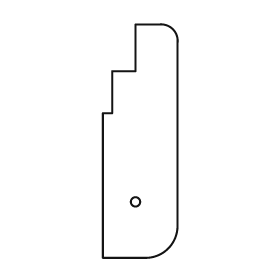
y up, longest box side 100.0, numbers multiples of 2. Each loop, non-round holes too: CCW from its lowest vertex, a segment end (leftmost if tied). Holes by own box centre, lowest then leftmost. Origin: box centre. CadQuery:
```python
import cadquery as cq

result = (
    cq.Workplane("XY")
    .moveTo(-16.0, -50.0)
    .lineTo(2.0, -50.0)
    .threePointArc((12.0, -46.0), (16.0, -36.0))
    .lineTo(16.0, 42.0)
    .threePointArc((14.0, 48.0), (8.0, 50.0))
    .lineTo(-2.0, 50.0)
    .lineTo(-2.0, 30.0)
    .lineTo(-12.0, 30.0)
    .lineTo(-12.0, 12.0)
    .lineTo(-16.0, 12.0)
    .close()
    .moveTo(-2.0, -26.0)
    .circle(2.0)
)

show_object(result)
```